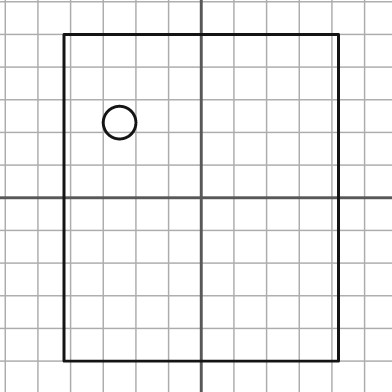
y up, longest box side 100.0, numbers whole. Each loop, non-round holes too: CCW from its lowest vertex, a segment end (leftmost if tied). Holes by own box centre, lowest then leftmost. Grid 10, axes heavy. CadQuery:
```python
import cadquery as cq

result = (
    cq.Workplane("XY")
    .moveTo(-42.0, -50.0)
    .lineTo(42.0, -50.0)
    .lineTo(42.0, 50.0)
    .lineTo(-42.0, 50.0)
    .close()
    .moveTo(-25.0, 23.0)
    .circle(5.0)
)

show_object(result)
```